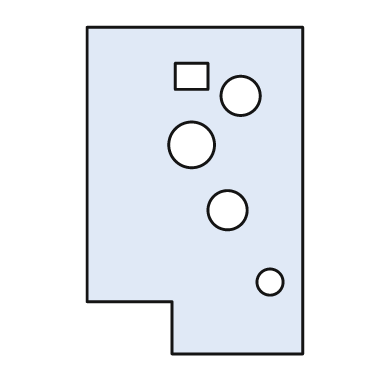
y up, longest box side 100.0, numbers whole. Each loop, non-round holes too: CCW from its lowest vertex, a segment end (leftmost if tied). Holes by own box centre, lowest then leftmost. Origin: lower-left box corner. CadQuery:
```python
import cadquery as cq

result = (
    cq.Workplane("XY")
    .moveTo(26.0, 0.0)
    .lineTo(66.0, 0.0)
    .lineTo(66.0, 100.0)
    .lineTo(0.0, 100.0)
    .lineTo(0.0, 16.0)
    .lineTo(26.0, 16.0)
    .close()
    .moveTo(56.0, 22.0)
    .circle(4.0)
    .moveTo(43.0, 44.0)
    .circle(6.0)
    .moveTo(32.0, 64.0)
    .circle(7.0)
    .moveTo(47.0, 79.0)
    .circle(6.0)
    .moveTo(27.0, 81.0)
    .lineTo(37.0, 81.0)
    .lineTo(37.0, 89.0)
    .lineTo(27.0, 89.0)
    .close()
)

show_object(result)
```